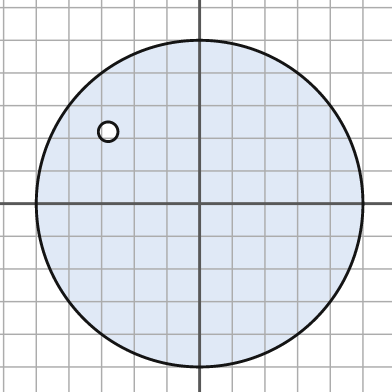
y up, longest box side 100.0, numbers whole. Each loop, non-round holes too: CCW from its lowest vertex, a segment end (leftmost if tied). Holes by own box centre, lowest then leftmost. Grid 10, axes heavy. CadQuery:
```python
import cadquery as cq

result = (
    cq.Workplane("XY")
    .moveTo(0.0, 0.0)
    .circle(50.0)
    .moveTo(-28.0, 22.0)
    .circle(3.0)
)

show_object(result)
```